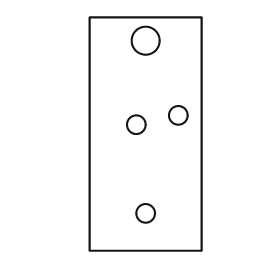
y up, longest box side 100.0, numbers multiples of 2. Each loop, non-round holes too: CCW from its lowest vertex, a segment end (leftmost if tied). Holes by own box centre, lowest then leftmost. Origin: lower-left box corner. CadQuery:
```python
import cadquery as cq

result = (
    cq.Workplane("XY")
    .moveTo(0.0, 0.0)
    .lineTo(48.0, 0.0)
    .lineTo(48.0, 100.0)
    .lineTo(0.0, 100.0)
    .close()
    .moveTo(24.0, 16.0)
    .circle(4.0)
    .moveTo(20.0, 54.0)
    .circle(4.0)
    .moveTo(38.0, 58.0)
    .circle(4.0)
    .moveTo(24.0, 90.0)
    .circle(6.0)
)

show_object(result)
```